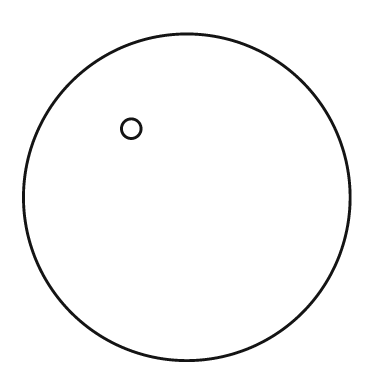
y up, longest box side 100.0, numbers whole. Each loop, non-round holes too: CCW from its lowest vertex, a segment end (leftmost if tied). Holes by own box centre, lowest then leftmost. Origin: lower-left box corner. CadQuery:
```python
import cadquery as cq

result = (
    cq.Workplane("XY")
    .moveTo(50.0, 50.0)
    .circle(50.0)
    .moveTo(33.0, 71.0)
    .circle(3.0)
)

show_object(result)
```